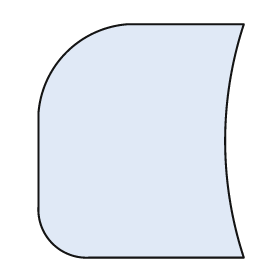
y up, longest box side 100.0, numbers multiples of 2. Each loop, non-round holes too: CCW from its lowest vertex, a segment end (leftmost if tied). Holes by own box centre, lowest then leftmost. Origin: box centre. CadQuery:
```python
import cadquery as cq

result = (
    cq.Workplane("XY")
    .moveTo(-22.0, -50.0)
    .lineTo(44.0, -50.0)
    .threePointArc((36.0, 0.0), (44.0, 50.0))
    .lineTo(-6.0, 50.0)
    .threePointArc((-32.0, 38.0), (-44.0, 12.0))
    .lineTo(-44.0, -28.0)
    .threePointArc((-38.0, -44.0), (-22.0, -50.0))
    .close()
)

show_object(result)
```